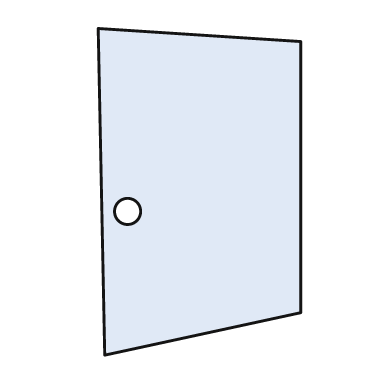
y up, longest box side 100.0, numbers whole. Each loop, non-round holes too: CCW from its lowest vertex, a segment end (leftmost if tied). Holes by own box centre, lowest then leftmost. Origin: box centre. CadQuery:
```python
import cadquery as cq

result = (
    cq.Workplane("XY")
    .moveTo(-29.0, -50.0)
    .lineTo(31.0, -37.0)
    .lineTo(31.0, 46.0)
    .lineTo(-31.0, 50.0)
    .close()
    .moveTo(-22.0, -6.0)
    .circle(4.0)
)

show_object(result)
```